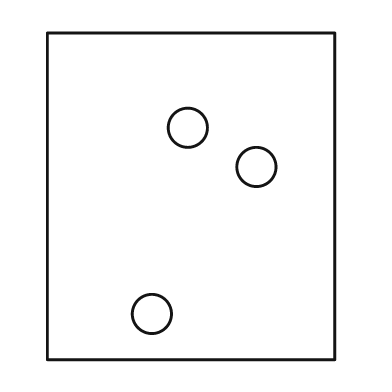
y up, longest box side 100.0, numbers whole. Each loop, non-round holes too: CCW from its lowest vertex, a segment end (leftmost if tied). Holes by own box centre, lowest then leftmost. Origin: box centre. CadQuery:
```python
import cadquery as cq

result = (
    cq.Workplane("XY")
    .moveTo(-44.0, -50.0)
    .lineTo(44.0, -50.0)
    .lineTo(44.0, 50.0)
    .lineTo(-44.0, 50.0)
    .close()
    .moveTo(-12.0, -36.0)
    .circle(6.0)
    .moveTo(20.0, 9.0)
    .circle(6.0)
    .moveTo(-1.0, 21.0)
    .circle(6.0)
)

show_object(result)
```